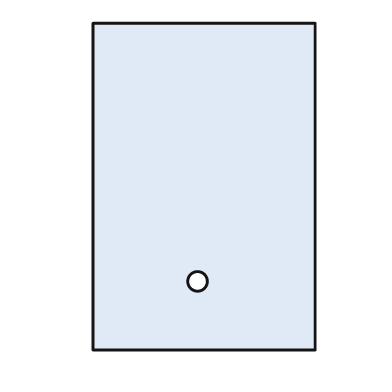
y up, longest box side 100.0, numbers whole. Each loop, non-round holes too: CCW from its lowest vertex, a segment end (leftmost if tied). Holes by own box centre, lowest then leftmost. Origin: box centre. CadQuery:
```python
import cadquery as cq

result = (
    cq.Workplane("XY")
    .moveTo(-34.0, -50.0)
    .lineTo(34.0, -50.0)
    .lineTo(34.0, 50.0)
    .lineTo(-34.0, 50.0)
    .close()
    .moveTo(-2.0, -29.0)
    .circle(3.0)
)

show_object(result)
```